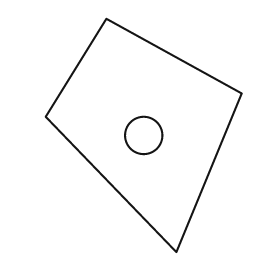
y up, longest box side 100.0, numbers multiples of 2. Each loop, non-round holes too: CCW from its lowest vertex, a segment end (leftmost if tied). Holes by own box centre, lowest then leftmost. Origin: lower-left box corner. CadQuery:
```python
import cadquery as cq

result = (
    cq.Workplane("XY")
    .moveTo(56.0, 0.0)
    .lineTo(84.0, 68.0)
    .lineTo(26.0, 100.0)
    .lineTo(0.0, 58.0)
    .close()
    .moveTo(42.0, 50.0)
    .circle(8.0)
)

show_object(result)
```